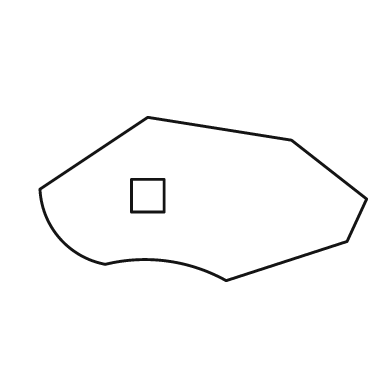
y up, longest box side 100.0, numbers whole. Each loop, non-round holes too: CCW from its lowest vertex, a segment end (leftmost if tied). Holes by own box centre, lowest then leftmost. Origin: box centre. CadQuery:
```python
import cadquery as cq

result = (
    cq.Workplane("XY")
    .moveTo(7.0, -25.0)
    .lineTo(44.0, -13.0)
    .lineTo(50.0, 0.0)
    .lineTo(27.0, 18.0)
    .lineTo(-17.0, 25.0)
    .lineTo(-50.0, 3.0)
    .threePointArc((-44.0, -12.0), (-30.0, -20.0))
    .threePointArc((-11.0, -19.0), (7.0, -25.0))
    .close()
    .moveTo(-22.0, -4.0)
    .lineTo(-12.0, -4.0)
    .lineTo(-12.0, 6.0)
    .lineTo(-22.0, 6.0)
    .close()
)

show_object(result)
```